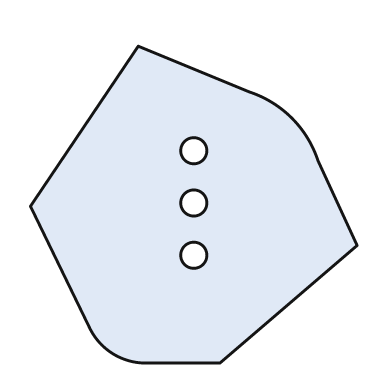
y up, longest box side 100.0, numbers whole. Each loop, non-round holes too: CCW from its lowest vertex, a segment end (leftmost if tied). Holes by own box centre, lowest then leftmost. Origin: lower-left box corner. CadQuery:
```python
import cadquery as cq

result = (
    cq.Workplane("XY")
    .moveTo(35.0, 0.0)
    .lineTo(58.0, 0.0)
    .lineTo(100.0, 36.0)
    .lineTo(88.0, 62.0)
    .threePointArc((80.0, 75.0), (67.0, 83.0))
    .lineTo(33.0, 97.0)
    .lineTo(0.0, 48.0)
    .lineTo(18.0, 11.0)
    .threePointArc((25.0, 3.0), (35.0, 0.0))
    .close()
    .moveTo(50.0, 33.0)
    .circle(4.0)
    .moveTo(50.0, 49.0)
    .circle(4.0)
    .moveTo(50.0, 65.0)
    .circle(4.0)
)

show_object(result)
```